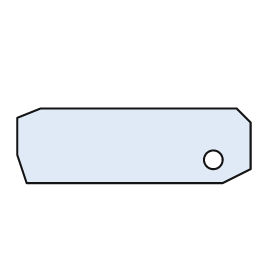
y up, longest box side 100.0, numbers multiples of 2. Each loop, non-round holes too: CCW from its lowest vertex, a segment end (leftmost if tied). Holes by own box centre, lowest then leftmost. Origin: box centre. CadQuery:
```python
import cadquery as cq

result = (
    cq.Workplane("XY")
    .moveTo(-46.0, -16.0)
    .lineTo(38.0, -16.0)
    .lineTo(50.0, -10.0)
    .lineTo(50.0, 10.0)
    .lineTo(44.0, 16.0)
    .lineTo(-40.0, 16.0)
    .lineTo(-50.0, 12.0)
    .lineTo(-50.0, -4.0)
    .close()
    .moveTo(34.0, -6.0)
    .circle(4.0)
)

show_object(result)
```